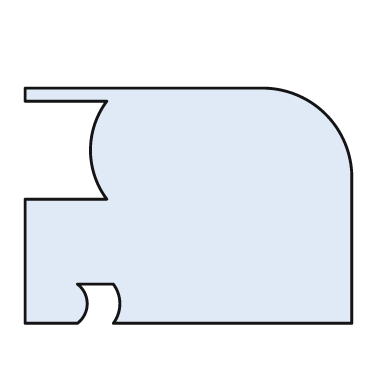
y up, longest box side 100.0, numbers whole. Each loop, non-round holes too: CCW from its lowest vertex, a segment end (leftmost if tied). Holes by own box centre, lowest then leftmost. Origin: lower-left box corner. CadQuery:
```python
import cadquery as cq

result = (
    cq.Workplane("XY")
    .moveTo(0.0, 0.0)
    .lineTo(16.0, 0.0)
    .threePointArc((19.0, 6.0), (16.0, 12.0))
    .lineTo(27.0, 12.0)
    .threePointArc((29.0, 6.0), (27.0, 0.0))
    .lineTo(100.0, 0.0)
    .lineTo(100.0, 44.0)
    .threePointArc((92.0, 64.0), (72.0, 72.0))
    .lineTo(0.0, 72.0)
    .lineTo(0.0, 68.0)
    .lineTo(25.0, 68.0)
    .threePointArc((20.0, 53.0), (25.0, 38.0))
    .lineTo(0.0, 38.0)
    .close()
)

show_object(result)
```